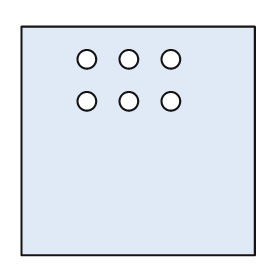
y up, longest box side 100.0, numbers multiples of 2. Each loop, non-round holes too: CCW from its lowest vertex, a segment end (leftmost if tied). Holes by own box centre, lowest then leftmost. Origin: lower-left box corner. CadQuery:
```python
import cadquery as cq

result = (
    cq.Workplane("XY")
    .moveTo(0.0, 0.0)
    .lineTo(100.0, 0.0)
    .lineTo(100.0, 98.0)
    .lineTo(0.0, 98.0)
    .close()
    .moveTo(28.0, 66.0)
    .circle(4.0)
    .moveTo(46.0, 66.0)
    .circle(4.0)
    .moveTo(64.0, 66.0)
    .circle(4.0)
    .moveTo(28.0, 84.0)
    .circle(4.0)
    .moveTo(46.0, 84.0)
    .circle(4.0)
    .moveTo(64.0, 84.0)
    .circle(4.0)
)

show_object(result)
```